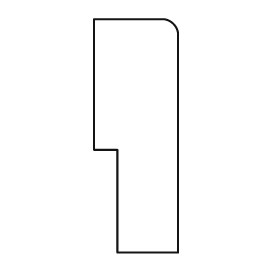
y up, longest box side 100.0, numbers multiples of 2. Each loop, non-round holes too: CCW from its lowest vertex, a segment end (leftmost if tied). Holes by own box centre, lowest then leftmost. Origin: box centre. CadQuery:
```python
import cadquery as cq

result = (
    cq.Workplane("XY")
    .moveTo(-8.0, -50.0)
    .lineTo(18.0, -50.0)
    .lineTo(18.0, 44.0)
    .threePointArc((16.0, 48.0), (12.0, 50.0))
    .lineTo(-18.0, 50.0)
    .lineTo(-18.0, -6.0)
    .lineTo(-8.0, -6.0)
    .close()
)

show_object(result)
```